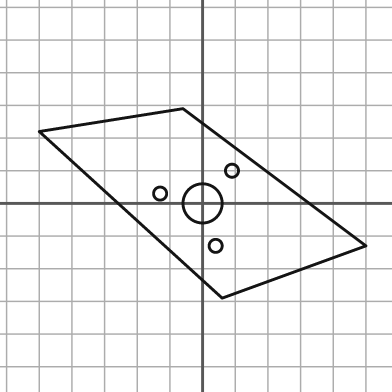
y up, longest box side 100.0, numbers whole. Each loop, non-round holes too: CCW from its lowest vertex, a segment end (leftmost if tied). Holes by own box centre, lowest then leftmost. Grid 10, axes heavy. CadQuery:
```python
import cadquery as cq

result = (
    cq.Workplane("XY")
    .moveTo(6.0, -29.0)
    .lineTo(50.0, -13.0)
    .lineTo(-6.0, 29.0)
    .lineTo(-50.0, 22.0)
    .close()
    .moveTo(4.0, -13.0)
    .circle(2.0)
    .moveTo(0.0, 0.0)
    .circle(6.0)
    .moveTo(-13.0, 3.0)
    .circle(2.0)
    .moveTo(9.0, 10.0)
    .circle(2.0)
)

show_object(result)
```